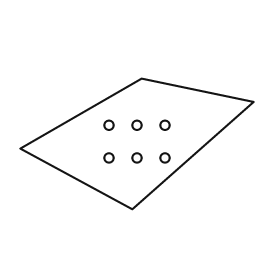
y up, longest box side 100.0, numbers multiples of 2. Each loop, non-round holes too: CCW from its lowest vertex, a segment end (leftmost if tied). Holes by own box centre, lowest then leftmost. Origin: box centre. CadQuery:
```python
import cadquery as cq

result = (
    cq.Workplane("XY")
    .moveTo(-2.0, -28.0)
    .lineTo(50.0, 18.0)
    .lineTo(2.0, 28.0)
    .lineTo(-50.0, -2.0)
    .close()
    .moveTo(-12.0, -6.0)
    .circle(2.0)
    .moveTo(0.0, -6.0)
    .circle(2.0)
    .moveTo(12.0, -6.0)
    .circle(2.0)
    .moveTo(-12.0, 8.0)
    .circle(2.0)
    .moveTo(0.0, 8.0)
    .circle(2.0)
    .moveTo(12.0, 8.0)
    .circle(2.0)
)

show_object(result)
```